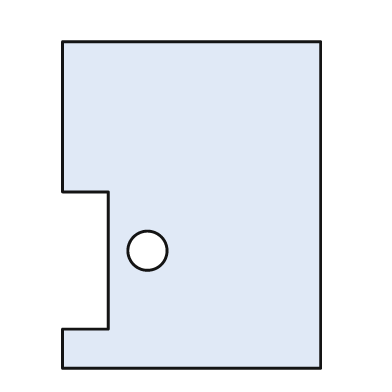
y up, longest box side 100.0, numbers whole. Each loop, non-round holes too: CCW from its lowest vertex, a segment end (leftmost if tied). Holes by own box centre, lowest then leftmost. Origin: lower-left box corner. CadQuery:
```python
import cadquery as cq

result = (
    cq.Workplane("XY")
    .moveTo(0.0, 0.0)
    .lineTo(79.0, 0.0)
    .lineTo(79.0, 100.0)
    .lineTo(0.0, 100.0)
    .lineTo(0.0, 54.0)
    .lineTo(14.0, 54.0)
    .lineTo(14.0, 12.0)
    .lineTo(0.0, 12.0)
    .close()
    .moveTo(26.0, 36.0)
    .circle(6.0)
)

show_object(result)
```